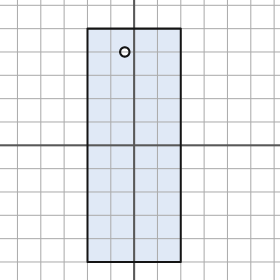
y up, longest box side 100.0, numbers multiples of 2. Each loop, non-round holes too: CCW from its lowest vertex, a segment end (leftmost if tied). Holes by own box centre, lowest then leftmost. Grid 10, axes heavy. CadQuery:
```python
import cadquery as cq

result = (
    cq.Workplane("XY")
    .moveTo(-20.0, -50.0)
    .lineTo(20.0, -50.0)
    .lineTo(20.0, 50.0)
    .lineTo(-20.0, 50.0)
    .close()
    .moveTo(-4.0, 40.0)
    .circle(2.0)
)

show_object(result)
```